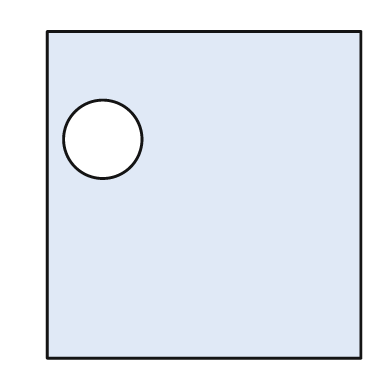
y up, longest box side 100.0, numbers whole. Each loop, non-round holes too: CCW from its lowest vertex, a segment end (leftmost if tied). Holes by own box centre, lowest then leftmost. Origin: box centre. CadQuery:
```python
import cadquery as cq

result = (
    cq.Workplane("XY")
    .moveTo(-48.0, -50.0)
    .lineTo(48.0, -50.0)
    .lineTo(48.0, 50.0)
    .lineTo(-48.0, 50.0)
    .close()
    .moveTo(-31.0, 17.0)
    .circle(12.0)
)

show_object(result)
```